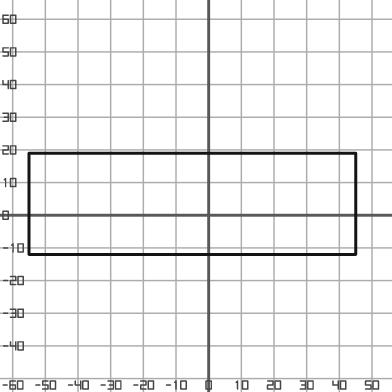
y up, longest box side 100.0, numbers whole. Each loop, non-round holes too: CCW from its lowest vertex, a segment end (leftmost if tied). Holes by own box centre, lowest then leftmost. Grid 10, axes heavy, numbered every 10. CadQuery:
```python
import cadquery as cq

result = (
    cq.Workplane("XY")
    .moveTo(-55.0, -12.0)
    .lineTo(45.0, -12.0)
    .lineTo(45.0, 19.0)
    .lineTo(-55.0, 19.0)
    .close()
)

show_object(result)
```